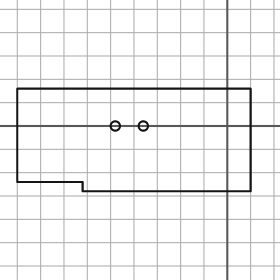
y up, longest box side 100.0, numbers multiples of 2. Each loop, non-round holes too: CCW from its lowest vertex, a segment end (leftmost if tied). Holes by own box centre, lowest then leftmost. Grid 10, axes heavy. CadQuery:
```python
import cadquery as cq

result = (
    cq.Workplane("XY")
    .moveTo(-62.0, -28.0)
    .lineTo(10.0, -28.0)
    .lineTo(10.0, 16.0)
    .lineTo(-90.0, 16.0)
    .lineTo(-90.0, -24.0)
    .lineTo(-62.0, -24.0)
    .close()
    .moveTo(-48.0, 0.0)
    .circle(2.0)
    .moveTo(-36.0, 0.0)
    .circle(2.0)
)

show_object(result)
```